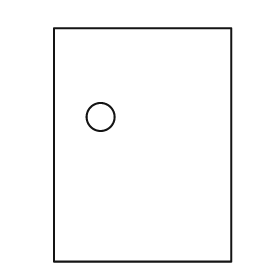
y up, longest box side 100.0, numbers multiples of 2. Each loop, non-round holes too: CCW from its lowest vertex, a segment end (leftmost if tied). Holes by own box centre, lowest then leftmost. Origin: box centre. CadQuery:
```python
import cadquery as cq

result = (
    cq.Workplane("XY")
    .moveTo(-38.0, -50.0)
    .lineTo(38.0, -50.0)
    .lineTo(38.0, 50.0)
    .lineTo(-38.0, 50.0)
    .close()
    .moveTo(-18.0, 12.0)
    .circle(6.0)
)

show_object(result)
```